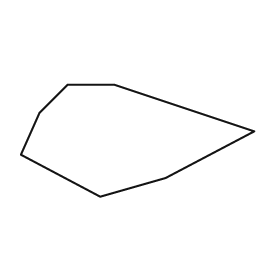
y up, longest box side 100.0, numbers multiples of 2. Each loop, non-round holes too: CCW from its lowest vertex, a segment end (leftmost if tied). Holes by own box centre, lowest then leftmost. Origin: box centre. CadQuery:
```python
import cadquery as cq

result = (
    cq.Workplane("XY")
    .moveTo(-16.0, -24.0)
    .lineTo(12.0, -16.0)
    .lineTo(50.0, 4.0)
    .lineTo(-10.0, 24.0)
    .lineTo(-30.0, 24.0)
    .lineTo(-42.0, 12.0)
    .lineTo(-50.0, -6.0)
    .close()
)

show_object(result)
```